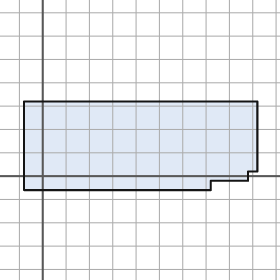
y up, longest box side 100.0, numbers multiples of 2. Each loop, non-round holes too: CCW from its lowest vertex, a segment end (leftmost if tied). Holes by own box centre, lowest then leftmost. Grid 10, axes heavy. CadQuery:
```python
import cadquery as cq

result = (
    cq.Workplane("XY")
    .moveTo(-8.0, -6.0)
    .lineTo(72.0, -6.0)
    .lineTo(72.0, -2.0)
    .lineTo(88.0, -2.0)
    .lineTo(88.0, 2.0)
    .lineTo(92.0, 2.0)
    .lineTo(92.0, 32.0)
    .lineTo(-8.0, 32.0)
    .close()
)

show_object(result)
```